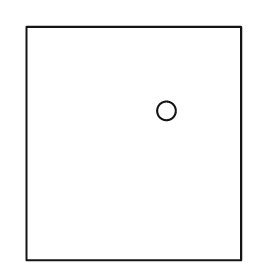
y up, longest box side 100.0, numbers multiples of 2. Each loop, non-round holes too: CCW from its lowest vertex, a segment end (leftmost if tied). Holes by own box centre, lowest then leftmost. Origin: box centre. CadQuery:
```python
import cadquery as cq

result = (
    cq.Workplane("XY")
    .moveTo(-46.0, -50.0)
    .lineTo(46.0, -50.0)
    .lineTo(46.0, 50.0)
    .lineTo(-46.0, 50.0)
    .close()
    .moveTo(14.0, 14.0)
    .circle(4.0)
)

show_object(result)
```